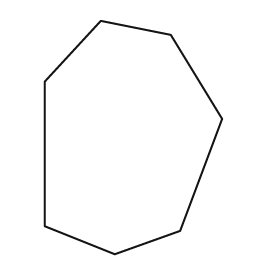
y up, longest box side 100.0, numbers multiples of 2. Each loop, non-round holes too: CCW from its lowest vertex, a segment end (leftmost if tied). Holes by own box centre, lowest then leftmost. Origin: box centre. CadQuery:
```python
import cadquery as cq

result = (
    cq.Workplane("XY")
    .moveTo(-8.0, -50.0)
    .lineTo(20.0, -40.0)
    .lineTo(38.0, 8.0)
    .lineTo(16.0, 44.0)
    .lineTo(-14.0, 50.0)
    .lineTo(-38.0, 24.0)
    .lineTo(-38.0, -38.0)
    .close()
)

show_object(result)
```